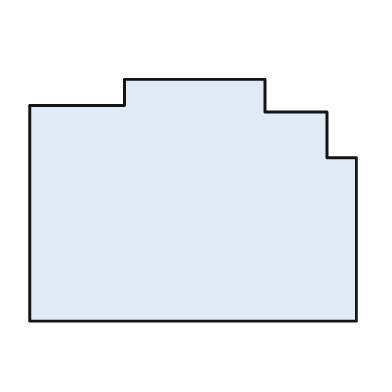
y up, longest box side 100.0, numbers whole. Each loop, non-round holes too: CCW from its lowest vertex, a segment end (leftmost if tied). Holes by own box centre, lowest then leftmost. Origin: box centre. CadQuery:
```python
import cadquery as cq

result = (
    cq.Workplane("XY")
    .moveTo(-50.0, -37.0)
    .lineTo(50.0, -37.0)
    .lineTo(50.0, 13.0)
    .lineTo(41.0, 13.0)
    .lineTo(41.0, 27.0)
    .lineTo(22.0, 27.0)
    .lineTo(22.0, 37.0)
    .lineTo(-21.0, 37.0)
    .lineTo(-21.0, 29.0)
    .lineTo(-50.0, 29.0)
    .close()
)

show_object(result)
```